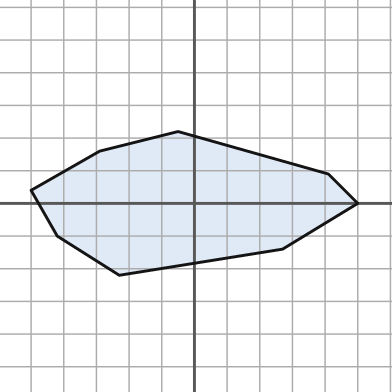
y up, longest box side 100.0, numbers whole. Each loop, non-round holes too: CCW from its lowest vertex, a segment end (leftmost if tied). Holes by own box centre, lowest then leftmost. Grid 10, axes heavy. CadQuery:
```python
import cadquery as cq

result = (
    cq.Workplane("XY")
    .moveTo(-23.0, -22.0)
    .lineTo(27.0, -14.0)
    .lineTo(50.0, 0.0)
    .lineTo(41.0, 9.0)
    .lineTo(-5.0, 22.0)
    .lineTo(-29.0, 16.0)
    .lineTo(-50.0, 4.0)
    .lineTo(-42.0, -10.0)
    .close()
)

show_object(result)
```